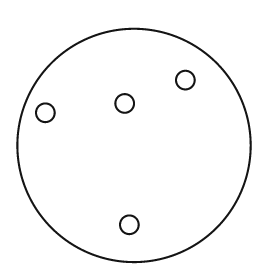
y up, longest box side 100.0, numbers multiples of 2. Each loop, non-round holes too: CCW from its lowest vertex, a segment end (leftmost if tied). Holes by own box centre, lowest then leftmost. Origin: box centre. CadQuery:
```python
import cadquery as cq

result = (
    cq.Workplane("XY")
    .moveTo(0.0, 0.0)
    .circle(50.0)
    .moveTo(-2.0, -34.0)
    .circle(4.0)
    .moveTo(-38.0, 14.0)
    .circle(4.0)
    .moveTo(-4.0, 18.0)
    .circle(4.0)
    .moveTo(22.0, 28.0)
    .circle(4.0)
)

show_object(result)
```